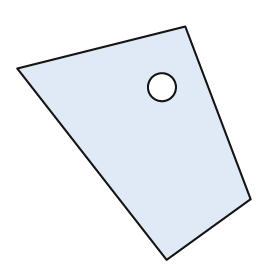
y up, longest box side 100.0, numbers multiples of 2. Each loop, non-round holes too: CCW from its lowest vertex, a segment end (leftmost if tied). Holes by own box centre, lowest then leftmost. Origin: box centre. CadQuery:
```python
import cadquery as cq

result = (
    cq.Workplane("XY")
    .moveTo(14.0, -50.0)
    .lineTo(50.0, -24.0)
    .lineTo(22.0, 50.0)
    .lineTo(-50.0, 32.0)
    .close()
    .moveTo(12.0, 24.0)
    .circle(6.0)
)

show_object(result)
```